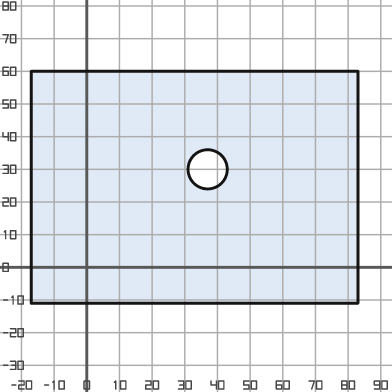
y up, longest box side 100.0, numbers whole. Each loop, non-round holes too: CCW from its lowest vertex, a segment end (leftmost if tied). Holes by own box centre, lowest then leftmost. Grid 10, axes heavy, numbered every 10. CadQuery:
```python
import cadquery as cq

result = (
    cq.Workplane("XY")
    .moveTo(-17.0, -11.0)
    .lineTo(83.0, -11.0)
    .lineTo(83.0, 60.0)
    .lineTo(-17.0, 60.0)
    .close()
    .moveTo(37.0, 30.0)
    .circle(6.0)
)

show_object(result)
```